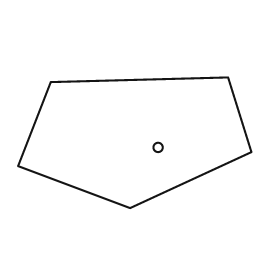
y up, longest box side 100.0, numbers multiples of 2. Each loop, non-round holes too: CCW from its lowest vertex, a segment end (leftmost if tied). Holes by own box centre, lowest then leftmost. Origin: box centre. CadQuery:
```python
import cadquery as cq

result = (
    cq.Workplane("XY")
    .moveTo(-2.0, -28.0)
    .lineTo(50.0, -4.0)
    .lineTo(40.0, 28.0)
    .lineTo(-36.0, 26.0)
    .lineTo(-50.0, -10.0)
    .close()
    .moveTo(10.0, -2.0)
    .circle(2.0)
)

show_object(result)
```